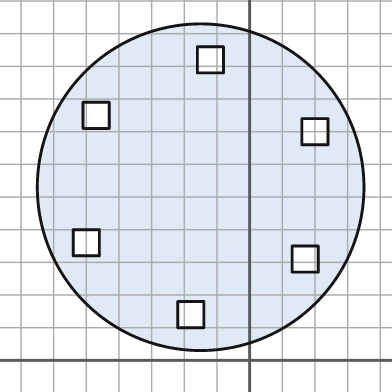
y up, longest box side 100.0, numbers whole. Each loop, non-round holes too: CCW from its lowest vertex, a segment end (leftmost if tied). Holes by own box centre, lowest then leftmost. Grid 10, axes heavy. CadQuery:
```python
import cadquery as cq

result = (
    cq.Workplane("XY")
    .moveTo(-15.0, 53.0)
    .circle(50.0)
    .moveTo(-22.0, 10.0)
    .lineTo(-14.0, 10.0)
    .lineTo(-14.0, 18.0)
    .lineTo(-22.0, 18.0)
    .close()
    .moveTo(13.0, 27.0)
    .lineTo(21.0, 27.0)
    .lineTo(21.0, 35.0)
    .lineTo(13.0, 35.0)
    .close()
    .moveTo(-54.0, 32.0)
    .lineTo(-46.0, 32.0)
    .lineTo(-46.0, 40.0)
    .lineTo(-54.0, 40.0)
    .close()
    .moveTo(16.0, 66.0)
    .lineTo(24.0, 66.0)
    .lineTo(24.0, 74.0)
    .lineTo(16.0, 74.0)
    .close()
    .moveTo(-51.0, 71.0)
    .lineTo(-43.0, 71.0)
    .lineTo(-43.0, 79.0)
    .lineTo(-51.0, 79.0)
    .close()
    .moveTo(-16.0, 88.0)
    .lineTo(-8.0, 88.0)
    .lineTo(-8.0, 96.0)
    .lineTo(-16.0, 96.0)
    .close()
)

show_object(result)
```